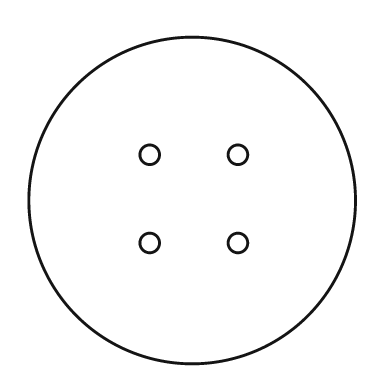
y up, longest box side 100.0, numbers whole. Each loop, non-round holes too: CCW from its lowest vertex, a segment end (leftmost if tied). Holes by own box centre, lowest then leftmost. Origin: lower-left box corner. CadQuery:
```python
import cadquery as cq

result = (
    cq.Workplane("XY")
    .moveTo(50.0, 50.0)
    .circle(50.0)
    .moveTo(37.0, 37.0)
    .circle(3.0)
    .moveTo(64.0, 37.0)
    .circle(3.0)
    .moveTo(37.0, 64.0)
    .circle(3.0)
    .moveTo(64.0, 64.0)
    .circle(3.0)
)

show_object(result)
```